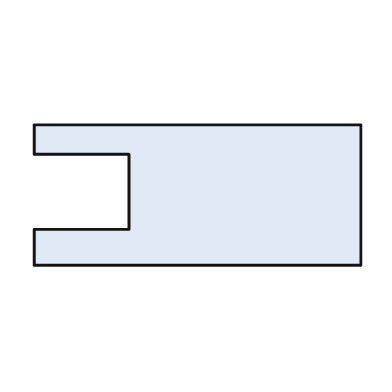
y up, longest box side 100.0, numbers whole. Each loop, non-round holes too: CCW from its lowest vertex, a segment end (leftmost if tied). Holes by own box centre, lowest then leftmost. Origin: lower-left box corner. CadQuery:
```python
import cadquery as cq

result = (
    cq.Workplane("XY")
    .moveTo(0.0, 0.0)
    .lineTo(100.0, 0.0)
    .lineTo(100.0, 43.0)
    .lineTo(0.0, 43.0)
    .lineTo(0.0, 34.0)
    .lineTo(29.0, 34.0)
    .lineTo(29.0, 11.0)
    .lineTo(0.0, 11.0)
    .close()
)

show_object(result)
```